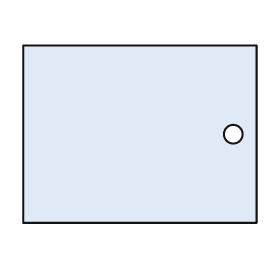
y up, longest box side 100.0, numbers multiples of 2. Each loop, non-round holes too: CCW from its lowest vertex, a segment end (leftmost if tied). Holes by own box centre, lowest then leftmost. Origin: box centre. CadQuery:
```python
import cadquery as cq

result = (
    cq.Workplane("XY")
    .moveTo(-50.0, -38.0)
    .lineTo(50.0, -38.0)
    .lineTo(50.0, 38.0)
    .lineTo(-50.0, 38.0)
    .close()
    .moveTo(40.0, 0.0)
    .circle(4.0)
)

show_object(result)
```